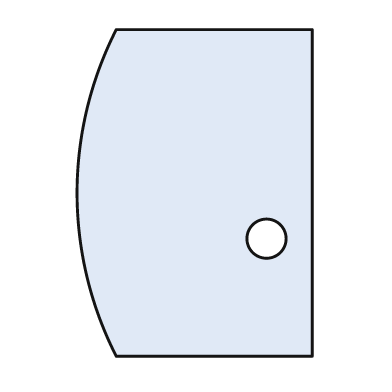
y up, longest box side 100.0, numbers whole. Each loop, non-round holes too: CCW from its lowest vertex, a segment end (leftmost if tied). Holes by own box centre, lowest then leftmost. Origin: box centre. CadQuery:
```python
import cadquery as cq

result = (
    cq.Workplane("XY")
    .moveTo(-24.0, -50.0)
    .lineTo(36.0, -50.0)
    .lineTo(36.0, 50.0)
    .lineTo(-24.0, 50.0)
    .threePointArc((-36.0, 0.0), (-24.0, -50.0))
    .close()
    .moveTo(22.0, -14.0)
    .circle(6.0)
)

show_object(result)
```